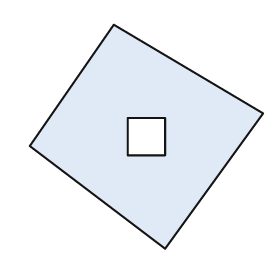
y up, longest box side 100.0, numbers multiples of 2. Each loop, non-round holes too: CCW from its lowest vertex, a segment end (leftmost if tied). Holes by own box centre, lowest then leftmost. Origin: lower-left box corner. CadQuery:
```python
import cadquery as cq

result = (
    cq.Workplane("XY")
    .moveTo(58.0, 0.0)
    .lineTo(100.0, 58.0)
    .lineTo(36.0, 96.0)
    .lineTo(0.0, 44.0)
    .close()
    .moveTo(42.0, 40.0)
    .lineTo(58.0, 40.0)
    .lineTo(58.0, 56.0)
    .lineTo(42.0, 56.0)
    .close()
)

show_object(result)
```